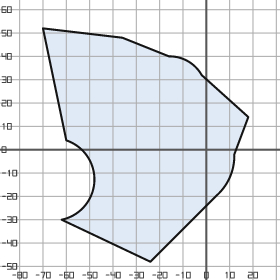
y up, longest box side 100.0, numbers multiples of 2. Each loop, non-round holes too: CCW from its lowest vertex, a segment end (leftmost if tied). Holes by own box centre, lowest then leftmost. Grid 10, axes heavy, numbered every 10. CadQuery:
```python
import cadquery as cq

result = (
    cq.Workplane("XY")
    .moveTo(-24.0, -48.0)
    .lineTo(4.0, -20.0)
    .threePointArc((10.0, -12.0), (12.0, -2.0))
    .lineTo(18.0, 14.0)
    .lineTo(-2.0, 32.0)
    .threePointArc((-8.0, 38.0), (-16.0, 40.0))
    .lineTo(-36.0, 48.0)
    .lineTo(-70.0, 52.0)
    .lineTo(-60.0, 4.0)
    .threePointArc((-48.0, -14.0), (-62.0, -30.0))
    .close()
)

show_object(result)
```